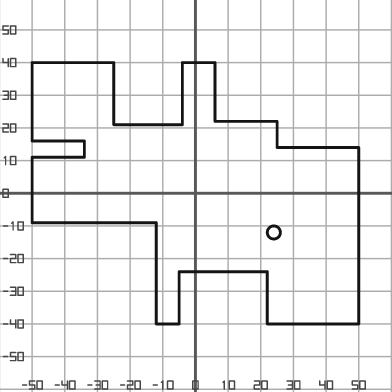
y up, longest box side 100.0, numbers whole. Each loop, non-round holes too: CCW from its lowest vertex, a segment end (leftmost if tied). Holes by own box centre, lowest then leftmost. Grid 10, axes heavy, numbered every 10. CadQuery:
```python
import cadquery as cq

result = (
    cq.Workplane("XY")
    .moveTo(-12.0, -40.0)
    .lineTo(-5.0, -40.0)
    .lineTo(-5.0, -24.0)
    .lineTo(22.0, -24.0)
    .lineTo(22.0, -40.0)
    .lineTo(50.0, -40.0)
    .lineTo(50.0, 14.0)
    .lineTo(25.0, 14.0)
    .lineTo(25.0, 22.0)
    .lineTo(6.0, 22.0)
    .lineTo(6.0, 40.0)
    .lineTo(-4.0, 40.0)
    .lineTo(-4.0, 21.0)
    .lineTo(-25.0, 21.0)
    .lineTo(-25.0, 40.0)
    .lineTo(-50.0, 40.0)
    .lineTo(-50.0, 16.0)
    .lineTo(-34.0, 16.0)
    .lineTo(-34.0, 11.0)
    .lineTo(-50.0, 11.0)
    .lineTo(-50.0, -9.0)
    .lineTo(-12.0, -9.0)
    .close()
    .moveTo(24.0, -12.0)
    .circle(2.0)
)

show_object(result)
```